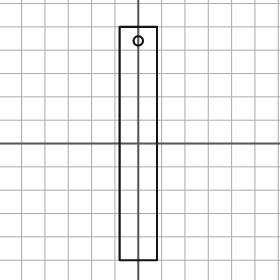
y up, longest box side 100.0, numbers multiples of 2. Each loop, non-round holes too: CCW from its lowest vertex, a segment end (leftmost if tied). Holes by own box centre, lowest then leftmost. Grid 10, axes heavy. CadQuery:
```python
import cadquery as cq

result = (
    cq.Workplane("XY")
    .moveTo(-8.0, -50.0)
    .lineTo(8.0, -50.0)
    .lineTo(8.0, 50.0)
    .lineTo(-8.0, 50.0)
    .close()
    .moveTo(0.0, 44.0)
    .circle(2.0)
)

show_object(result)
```